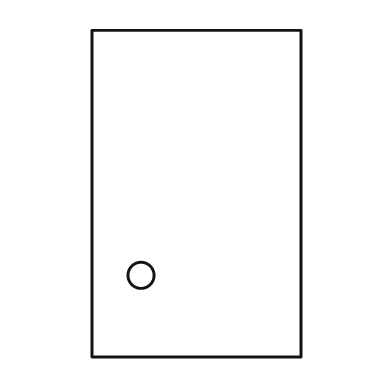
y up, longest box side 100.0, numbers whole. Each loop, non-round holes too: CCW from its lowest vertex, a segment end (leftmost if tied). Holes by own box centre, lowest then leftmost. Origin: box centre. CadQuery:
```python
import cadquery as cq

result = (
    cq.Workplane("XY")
    .moveTo(-32.0, -50.0)
    .lineTo(32.0, -50.0)
    .lineTo(32.0, 50.0)
    .lineTo(-32.0, 50.0)
    .close()
    .moveTo(-17.0, -25.0)
    .circle(4.0)
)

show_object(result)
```